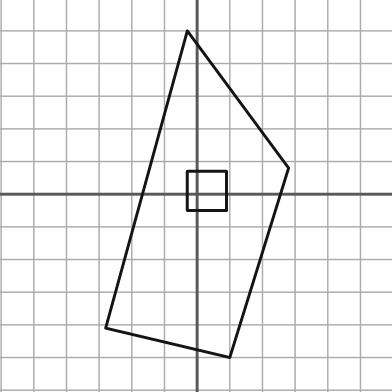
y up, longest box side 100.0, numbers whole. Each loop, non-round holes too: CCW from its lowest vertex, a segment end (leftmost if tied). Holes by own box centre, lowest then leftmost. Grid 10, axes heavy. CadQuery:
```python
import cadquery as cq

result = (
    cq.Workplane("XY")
    .moveTo(10.0, -50.0)
    .lineTo(28.0, 8.0)
    .lineTo(-3.0, 50.0)
    .lineTo(-28.0, -41.0)
    .close()
    .moveTo(-3.0, -5.0)
    .lineTo(9.0, -5.0)
    .lineTo(9.0, 7.0)
    .lineTo(-3.0, 7.0)
    .close()
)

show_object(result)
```